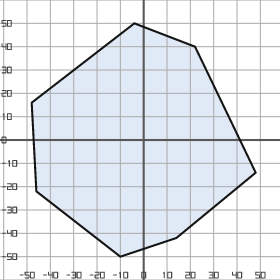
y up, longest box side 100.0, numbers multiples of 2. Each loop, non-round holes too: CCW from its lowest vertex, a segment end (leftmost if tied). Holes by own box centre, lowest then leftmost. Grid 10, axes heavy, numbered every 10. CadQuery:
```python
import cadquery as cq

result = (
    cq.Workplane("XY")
    .moveTo(-10.0, -50.0)
    .lineTo(14.0, -42.0)
    .lineTo(48.0, -14.0)
    .lineTo(22.0, 40.0)
    .lineTo(-4.0, 50.0)
    .lineTo(-48.0, 16.0)
    .lineTo(-46.0, -22.0)
    .close()
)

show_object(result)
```